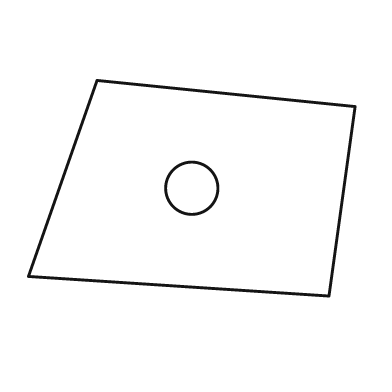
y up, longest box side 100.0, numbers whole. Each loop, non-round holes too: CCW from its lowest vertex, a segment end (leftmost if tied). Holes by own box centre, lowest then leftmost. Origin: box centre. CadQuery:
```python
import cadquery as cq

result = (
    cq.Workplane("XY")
    .moveTo(42.0, -33.0)
    .lineTo(50.0, 25.0)
    .lineTo(-29.0, 33.0)
    .lineTo(-50.0, -27.0)
    .close()
    .moveTo(0.0, 0.0)
    .circle(8.0)
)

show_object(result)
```